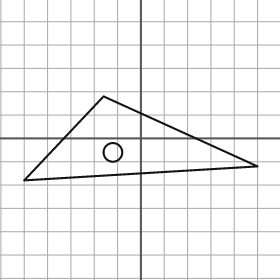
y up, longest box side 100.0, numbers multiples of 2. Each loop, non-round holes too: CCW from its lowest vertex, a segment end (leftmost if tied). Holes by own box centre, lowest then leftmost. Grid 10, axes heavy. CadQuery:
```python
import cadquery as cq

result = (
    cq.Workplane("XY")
    .moveTo(-50.0, -18.0)
    .lineTo(50.0, -12.0)
    .lineTo(-16.0, 18.0)
    .close()
    .moveTo(-12.0, -6.0)
    .circle(4.0)
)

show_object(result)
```